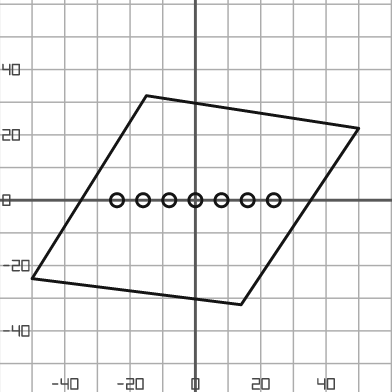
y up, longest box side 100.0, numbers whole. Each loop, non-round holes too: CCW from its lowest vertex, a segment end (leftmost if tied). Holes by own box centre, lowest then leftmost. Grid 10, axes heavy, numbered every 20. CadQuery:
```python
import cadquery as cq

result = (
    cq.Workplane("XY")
    .moveTo(14.0, -32.0)
    .lineTo(50.0, 22.0)
    .lineTo(-15.0, 32.0)
    .lineTo(-50.0, -24.0)
    .close()
    .moveTo(-24.0, 0.0)
    .circle(2.0)
    .moveTo(-16.0, 0.0)
    .circle(2.0)
    .moveTo(-8.0, 0.0)
    .circle(2.0)
    .moveTo(0.0, 0.0)
    .circle(2.0)
    .moveTo(8.0, 0.0)
    .circle(2.0)
    .moveTo(16.0, 0.0)
    .circle(2.0)
    .moveTo(24.0, 0.0)
    .circle(2.0)
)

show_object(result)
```